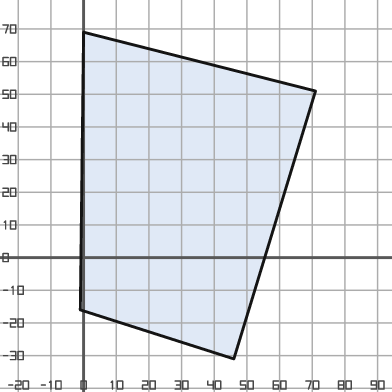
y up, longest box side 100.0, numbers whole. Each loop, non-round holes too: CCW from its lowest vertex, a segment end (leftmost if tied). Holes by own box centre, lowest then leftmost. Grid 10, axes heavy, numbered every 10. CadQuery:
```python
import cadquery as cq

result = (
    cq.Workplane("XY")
    .moveTo(46.0, -31.0)
    .lineTo(71.0, 51.0)
    .lineTo(0.0, 69.0)
    .lineTo(-1.0, -16.0)
    .close()
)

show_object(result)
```